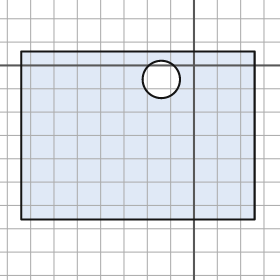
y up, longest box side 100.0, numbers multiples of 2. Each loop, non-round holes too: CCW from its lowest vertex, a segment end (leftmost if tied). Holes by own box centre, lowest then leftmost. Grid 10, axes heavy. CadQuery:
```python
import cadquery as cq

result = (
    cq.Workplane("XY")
    .moveTo(-74.0, -66.0)
    .lineTo(26.0, -66.0)
    .lineTo(26.0, 6.0)
    .lineTo(-74.0, 6.0)
    .close()
    .moveTo(-14.0, -6.0)
    .circle(8.0)
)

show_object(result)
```